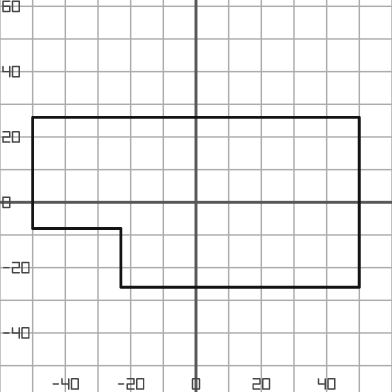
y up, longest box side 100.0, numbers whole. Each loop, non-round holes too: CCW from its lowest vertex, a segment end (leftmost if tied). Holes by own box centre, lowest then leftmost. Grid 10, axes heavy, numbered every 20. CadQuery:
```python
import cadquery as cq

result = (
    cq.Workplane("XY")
    .moveTo(-23.0, -26.0)
    .lineTo(50.0, -26.0)
    .lineTo(50.0, 26.0)
    .lineTo(-50.0, 26.0)
    .lineTo(-50.0, -8.0)
    .lineTo(-23.0, -8.0)
    .close()
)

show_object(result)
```